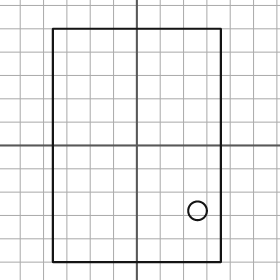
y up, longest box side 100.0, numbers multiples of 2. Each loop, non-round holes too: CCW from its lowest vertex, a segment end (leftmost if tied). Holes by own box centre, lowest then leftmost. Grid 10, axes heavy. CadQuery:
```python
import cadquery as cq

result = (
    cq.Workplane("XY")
    .moveTo(-36.0, -50.0)
    .lineTo(36.0, -50.0)
    .lineTo(36.0, 50.0)
    .lineTo(-36.0, 50.0)
    .close()
    .moveTo(26.0, -28.0)
    .circle(4.0)
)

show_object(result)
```